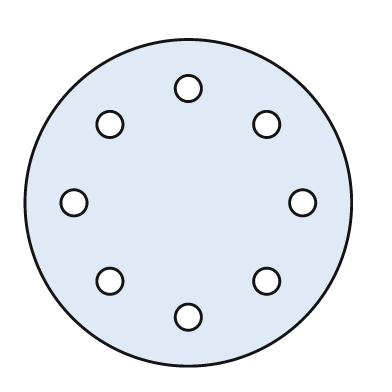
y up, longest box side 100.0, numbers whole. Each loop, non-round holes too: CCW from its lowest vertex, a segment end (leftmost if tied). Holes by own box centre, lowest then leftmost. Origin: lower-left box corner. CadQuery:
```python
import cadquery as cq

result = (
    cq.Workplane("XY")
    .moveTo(50.0, 50.0)
    .circle(50.0)
    .moveTo(50.0, 15.0)
    .circle(4.0)
    .moveTo(26.0, 26.0)
    .circle(4.0)
    .moveTo(74.0, 26.0)
    .circle(4.0)
    .moveTo(15.0, 50.0)
    .circle(4.0)
    .moveTo(85.0, 50.0)
    .circle(4.0)
    .moveTo(26.0, 74.0)
    .circle(4.0)
    .moveTo(74.0, 74.0)
    .circle(4.0)
    .moveTo(50.0, 85.0)
    .circle(4.0)
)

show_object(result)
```